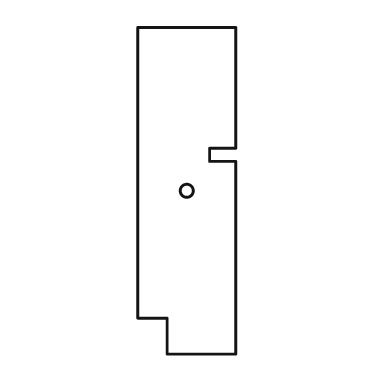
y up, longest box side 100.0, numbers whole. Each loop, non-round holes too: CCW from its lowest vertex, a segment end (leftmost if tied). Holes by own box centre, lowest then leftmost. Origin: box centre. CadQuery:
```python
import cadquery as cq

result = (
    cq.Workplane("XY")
    .moveTo(-6.0, -50.0)
    .lineTo(15.0, -50.0)
    .lineTo(15.0, 9.0)
    .lineTo(7.0, 9.0)
    .lineTo(7.0, 13.0)
    .lineTo(15.0, 13.0)
    .lineTo(15.0, 50.0)
    .lineTo(-15.0, 50.0)
    .lineTo(-15.0, -39.0)
    .lineTo(-6.0, -39.0)
    .close()
    .moveTo(0.0, 0.0)
    .circle(2.0)
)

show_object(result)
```